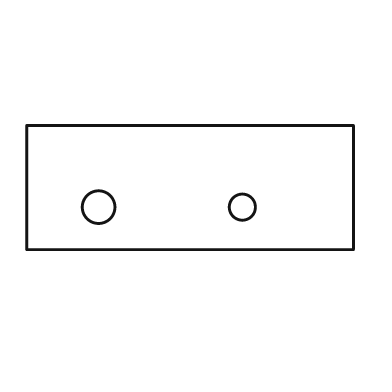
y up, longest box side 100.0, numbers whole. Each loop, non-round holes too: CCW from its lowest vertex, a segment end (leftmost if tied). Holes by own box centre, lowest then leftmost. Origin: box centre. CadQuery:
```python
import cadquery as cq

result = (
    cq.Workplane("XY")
    .moveTo(-50.0, -19.0)
    .lineTo(50.0, -19.0)
    .lineTo(50.0, 19.0)
    .lineTo(-50.0, 19.0)
    .close()
    .moveTo(-28.0, -6.0)
    .circle(5.0)
    .moveTo(16.0, -6.0)
    .circle(4.0)
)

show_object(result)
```